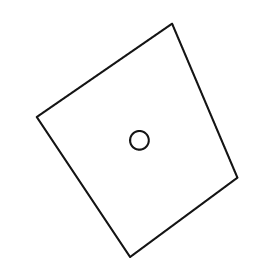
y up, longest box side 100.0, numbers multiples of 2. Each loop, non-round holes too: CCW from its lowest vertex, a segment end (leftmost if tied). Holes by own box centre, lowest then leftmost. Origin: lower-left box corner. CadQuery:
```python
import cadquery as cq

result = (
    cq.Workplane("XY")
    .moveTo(40.0, 0.0)
    .lineTo(86.0, 34.0)
    .lineTo(58.0, 100.0)
    .lineTo(0.0, 60.0)
    .close()
    .moveTo(44.0, 50.0)
    .circle(4.0)
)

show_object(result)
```